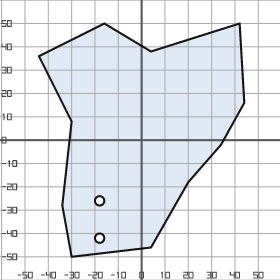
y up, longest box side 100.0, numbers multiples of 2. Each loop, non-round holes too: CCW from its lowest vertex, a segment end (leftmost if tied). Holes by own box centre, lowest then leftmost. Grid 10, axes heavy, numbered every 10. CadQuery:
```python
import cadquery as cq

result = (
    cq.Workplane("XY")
    .moveTo(-30.0, -50.0)
    .lineTo(4.0, -46.0)
    .lineTo(20.0, -18.0)
    .lineTo(34.0, -2.0)
    .lineTo(44.0, 16.0)
    .lineTo(42.0, 50.0)
    .lineTo(4.0, 38.0)
    .lineTo(-16.0, 50.0)
    .lineTo(-44.0, 36.0)
    .lineTo(-30.0, 8.0)
    .lineTo(-34.0, -28.0)
    .close()
    .moveTo(-18.0, -42.0)
    .circle(2.0)
    .moveTo(-18.0, -26.0)
    .circle(2.0)
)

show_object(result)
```